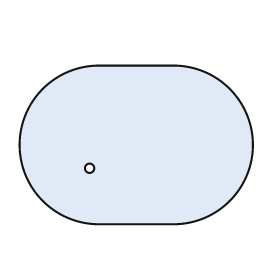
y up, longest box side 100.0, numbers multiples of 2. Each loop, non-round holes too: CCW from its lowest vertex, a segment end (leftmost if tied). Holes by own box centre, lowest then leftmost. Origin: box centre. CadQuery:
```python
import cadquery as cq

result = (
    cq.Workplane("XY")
    .moveTo(-16.0, -34.0)
    .lineTo(16.0, -34.0)
    .threePointArc((50.0, 0.0), (16.0, 34.0))
    .lineTo(-16.0, 34.0)
    .threePointArc((-50.0, 0.0), (-16.0, -34.0))
    .close()
    .moveTo(-20.0, -10.0)
    .circle(2.0)
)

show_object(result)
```